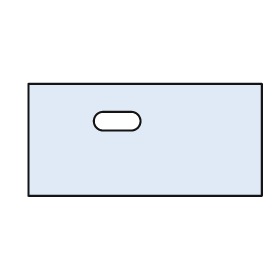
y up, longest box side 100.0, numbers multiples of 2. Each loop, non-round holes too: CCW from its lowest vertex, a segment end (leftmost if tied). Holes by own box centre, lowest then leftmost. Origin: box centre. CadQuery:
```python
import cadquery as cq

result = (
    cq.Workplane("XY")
    .moveTo(-50.0, -24.0)
    .lineTo(50.0, -24.0)
    .lineTo(50.0, 24.0)
    .lineTo(-50.0, 24.0)
    .close()
    .moveTo(-18.0, 4.0)
    .lineTo(-6.0, 4.0)
    .threePointArc((-2.0, 8.0), (-6.0, 12.0))
    .lineTo(-18.0, 12.0)
    .threePointArc((-22.0, 8.0), (-18.0, 4.0))
    .close()
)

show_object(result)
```